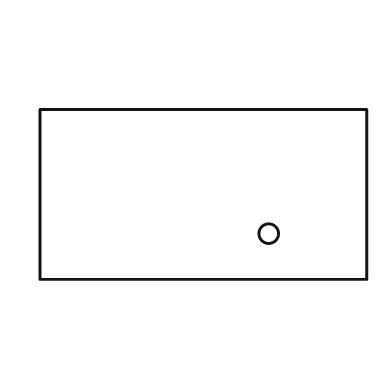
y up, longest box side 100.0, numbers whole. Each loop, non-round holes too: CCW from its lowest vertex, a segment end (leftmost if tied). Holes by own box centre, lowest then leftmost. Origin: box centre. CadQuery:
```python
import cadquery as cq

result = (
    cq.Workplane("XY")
    .moveTo(-50.0, -26.0)
    .lineTo(50.0, -26.0)
    .lineTo(50.0, 26.0)
    .lineTo(-50.0, 26.0)
    .close()
    .moveTo(20.0, -12.0)
    .circle(3.0)
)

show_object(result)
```